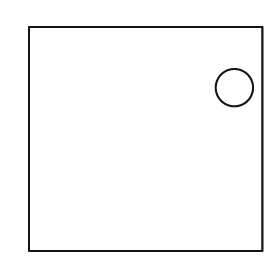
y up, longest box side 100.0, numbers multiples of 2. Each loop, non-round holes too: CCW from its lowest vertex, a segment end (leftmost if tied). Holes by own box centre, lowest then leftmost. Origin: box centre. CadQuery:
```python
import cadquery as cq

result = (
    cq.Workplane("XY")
    .moveTo(-50.0, -48.0)
    .lineTo(50.0, -48.0)
    .lineTo(50.0, 48.0)
    .lineTo(-50.0, 48.0)
    .close()
    .moveTo(38.0, 22.0)
    .circle(8.0)
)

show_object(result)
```